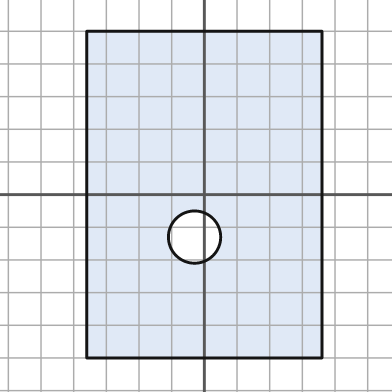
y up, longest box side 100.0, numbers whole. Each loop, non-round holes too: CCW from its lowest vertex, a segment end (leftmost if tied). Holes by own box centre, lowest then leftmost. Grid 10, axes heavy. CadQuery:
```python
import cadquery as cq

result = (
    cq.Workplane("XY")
    .moveTo(-36.0, -50.0)
    .lineTo(36.0, -50.0)
    .lineTo(36.0, 50.0)
    .lineTo(-36.0, 50.0)
    .close()
    .moveTo(-3.0, -13.0)
    .circle(8.0)
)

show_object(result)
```